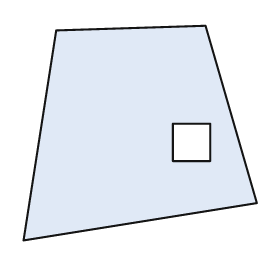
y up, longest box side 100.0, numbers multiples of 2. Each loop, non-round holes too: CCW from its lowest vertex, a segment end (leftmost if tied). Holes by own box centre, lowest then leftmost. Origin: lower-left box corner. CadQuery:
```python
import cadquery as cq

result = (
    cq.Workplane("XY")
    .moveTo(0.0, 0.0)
    .lineTo(100.0, 16.0)
    .lineTo(78.0, 92.0)
    .lineTo(14.0, 90.0)
    .close()
    .moveTo(64.0, 34.0)
    .lineTo(80.0, 34.0)
    .lineTo(80.0, 50.0)
    .lineTo(64.0, 50.0)
    .close()
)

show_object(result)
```